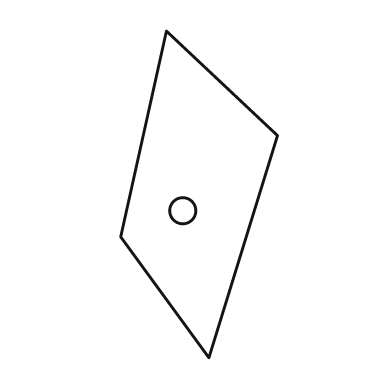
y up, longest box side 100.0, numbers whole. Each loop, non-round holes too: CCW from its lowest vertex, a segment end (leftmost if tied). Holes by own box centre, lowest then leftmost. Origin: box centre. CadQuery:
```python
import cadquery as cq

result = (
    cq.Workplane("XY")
    .moveTo(3.0, -50.0)
    .lineTo(24.0, 18.0)
    .lineTo(-10.0, 50.0)
    .lineTo(-24.0, -13.0)
    .close()
    .moveTo(-5.0, -5.0)
    .circle(4.0)
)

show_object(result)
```